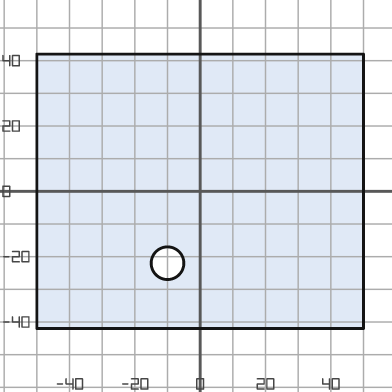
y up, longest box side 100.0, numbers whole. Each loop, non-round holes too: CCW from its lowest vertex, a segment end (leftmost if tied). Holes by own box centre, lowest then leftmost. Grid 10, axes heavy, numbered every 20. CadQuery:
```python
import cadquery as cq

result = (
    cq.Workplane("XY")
    .moveTo(-50.0, -42.0)
    .lineTo(50.0, -42.0)
    .lineTo(50.0, 42.0)
    .lineTo(-50.0, 42.0)
    .close()
    .moveTo(-10.0, -22.0)
    .circle(5.0)
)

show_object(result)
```